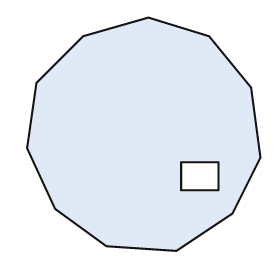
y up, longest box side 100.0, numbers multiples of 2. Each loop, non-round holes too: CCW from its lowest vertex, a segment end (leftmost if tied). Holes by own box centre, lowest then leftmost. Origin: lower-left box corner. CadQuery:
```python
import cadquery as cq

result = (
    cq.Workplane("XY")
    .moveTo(64.0, 0.0)
    .lineTo(88.0, 16.0)
    .lineTo(100.0, 40.0)
    .lineTo(96.0, 70.0)
    .lineTo(78.0, 92.0)
    .lineTo(52.0, 100.0)
    .lineTo(24.0, 92.0)
    .lineTo(4.0, 72.0)
    .lineTo(0.0, 44.0)
    .lineTo(12.0, 18.0)
    .lineTo(34.0, 2.0)
    .close()
    .moveTo(66.0, 26.0)
    .lineTo(82.0, 26.0)
    .lineTo(82.0, 38.0)
    .lineTo(66.0, 38.0)
    .close()
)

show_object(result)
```